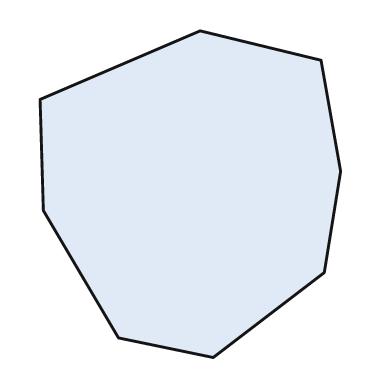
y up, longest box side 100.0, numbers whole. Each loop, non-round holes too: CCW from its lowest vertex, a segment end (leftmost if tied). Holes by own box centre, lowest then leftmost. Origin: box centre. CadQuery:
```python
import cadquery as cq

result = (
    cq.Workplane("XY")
    .moveTo(7.0, -50.0)
    .lineTo(41.0, -24.0)
    .lineTo(46.0, 7.0)
    .lineTo(40.0, 41.0)
    .lineTo(3.0, 50.0)
    .lineTo(-46.0, 29.0)
    .lineTo(-45.0, -5.0)
    .lineTo(-22.0, -44.0)
    .close()
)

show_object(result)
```